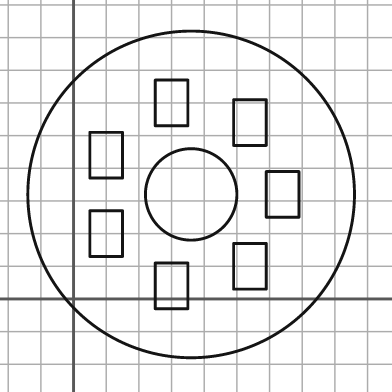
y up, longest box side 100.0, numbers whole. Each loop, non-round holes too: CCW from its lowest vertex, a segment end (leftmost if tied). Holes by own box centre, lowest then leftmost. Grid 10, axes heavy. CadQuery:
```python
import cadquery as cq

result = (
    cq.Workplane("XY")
    .moveTo(36.0, 32.0)
    .circle(50.0)
    .moveTo(25.0, -3.0)
    .lineTo(35.0, -3.0)
    .lineTo(35.0, 11.0)
    .lineTo(25.0, 11.0)
    .close()
    .moveTo(49.0, 3.0)
    .lineTo(59.0, 3.0)
    .lineTo(59.0, 17.0)
    .lineTo(49.0, 17.0)
    .close()
    .moveTo(5.0, 13.0)
    .lineTo(15.0, 13.0)
    .lineTo(15.0, 27.0)
    .lineTo(5.0, 27.0)
    .close()
    .moveTo(36.0, 32.0)
    .circle(14.0)
    .moveTo(59.0, 25.0)
    .lineTo(69.0, 25.0)
    .lineTo(69.0, 39.0)
    .lineTo(59.0, 39.0)
    .close()
    .moveTo(5.0, 37.0)
    .lineTo(15.0, 37.0)
    .lineTo(15.0, 51.0)
    .lineTo(5.0, 51.0)
    .close()
    .moveTo(49.0, 47.0)
    .lineTo(59.0, 47.0)
    .lineTo(59.0, 61.0)
    .lineTo(49.0, 61.0)
    .close()
    .moveTo(25.0, 53.0)
    .lineTo(35.0, 53.0)
    .lineTo(35.0, 67.0)
    .lineTo(25.0, 67.0)
    .close()
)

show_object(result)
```